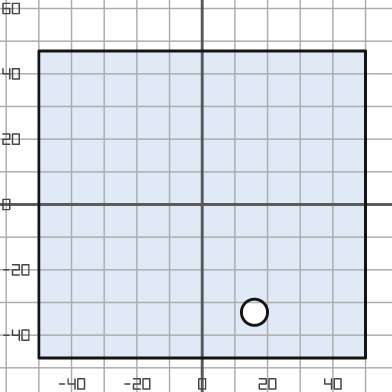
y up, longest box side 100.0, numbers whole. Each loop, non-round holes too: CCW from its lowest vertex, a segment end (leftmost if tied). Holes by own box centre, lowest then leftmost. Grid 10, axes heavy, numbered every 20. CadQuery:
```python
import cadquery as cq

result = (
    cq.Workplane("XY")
    .moveTo(-50.0, -47.0)
    .lineTo(50.0, -47.0)
    .lineTo(50.0, 47.0)
    .lineTo(-50.0, 47.0)
    .close()
    .moveTo(16.0, -33.0)
    .circle(4.0)
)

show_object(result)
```